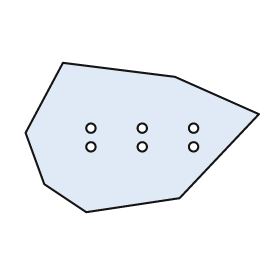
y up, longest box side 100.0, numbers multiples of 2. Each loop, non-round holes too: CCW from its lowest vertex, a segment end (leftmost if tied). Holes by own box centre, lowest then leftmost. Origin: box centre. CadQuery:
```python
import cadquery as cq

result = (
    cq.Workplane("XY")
    .moveTo(-24.0, -32.0)
    .lineTo(16.0, -26.0)
    .lineTo(50.0, 10.0)
    .lineTo(14.0, 26.0)
    .lineTo(-34.0, 32.0)
    .lineTo(-50.0, 2.0)
    .lineTo(-42.0, -20.0)
    .close()
    .moveTo(-22.0, -4.0)
    .circle(2.0)
    .moveTo(0.0, -4.0)
    .circle(2.0)
    .moveTo(22.0, -4.0)
    .circle(2.0)
    .moveTo(-22.0, 4.0)
    .circle(2.0)
    .moveTo(0.0, 4.0)
    .circle(2.0)
    .moveTo(22.0, 4.0)
    .circle(2.0)
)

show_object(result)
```